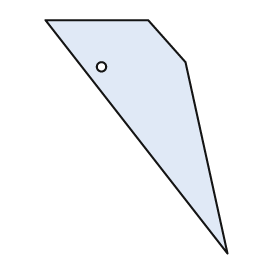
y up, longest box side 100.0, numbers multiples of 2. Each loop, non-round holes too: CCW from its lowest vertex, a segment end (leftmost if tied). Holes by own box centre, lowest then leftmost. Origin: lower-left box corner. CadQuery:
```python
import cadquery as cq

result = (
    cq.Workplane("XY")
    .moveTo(78.0, 0.0)
    .lineTo(60.0, 82.0)
    .lineTo(44.0, 100.0)
    .lineTo(0.0, 100.0)
    .close()
    .moveTo(24.0, 80.0)
    .circle(2.0)
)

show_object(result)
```